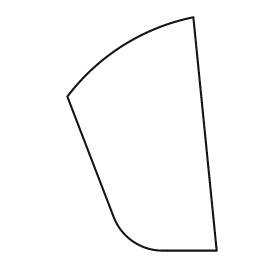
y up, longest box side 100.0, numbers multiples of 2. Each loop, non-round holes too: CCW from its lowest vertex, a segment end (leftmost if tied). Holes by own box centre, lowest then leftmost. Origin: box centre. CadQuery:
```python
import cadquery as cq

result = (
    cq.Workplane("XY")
    .moveTo(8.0, -50.0)
    .lineTo(32.0, -50.0)
    .lineTo(22.0, 50.0)
    .threePointArc((-8.0, 38.0), (-32.0, 16.0))
    .lineTo(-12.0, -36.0)
    .threePointArc((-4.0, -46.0), (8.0, -50.0))
    .close()
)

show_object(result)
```